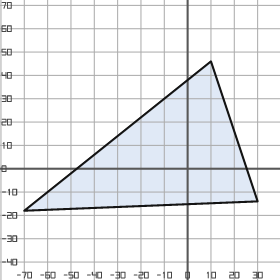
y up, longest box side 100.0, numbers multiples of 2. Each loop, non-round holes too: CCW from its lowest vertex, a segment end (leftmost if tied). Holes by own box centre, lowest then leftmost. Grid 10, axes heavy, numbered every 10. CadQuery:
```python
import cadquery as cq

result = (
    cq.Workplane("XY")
    .moveTo(-70.0, -18.0)
    .lineTo(30.0, -14.0)
    .lineTo(10.0, 46.0)
    .close()
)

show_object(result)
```